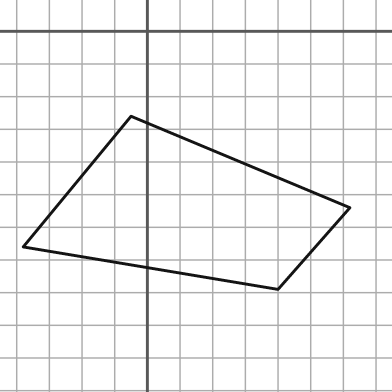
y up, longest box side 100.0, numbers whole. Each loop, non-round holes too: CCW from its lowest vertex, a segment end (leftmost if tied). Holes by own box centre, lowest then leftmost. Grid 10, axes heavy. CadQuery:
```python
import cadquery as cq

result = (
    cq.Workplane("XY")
    .moveTo(40.0, -79.0)
    .lineTo(62.0, -54.0)
    .lineTo(-5.0, -26.0)
    .lineTo(-38.0, -66.0)
    .close()
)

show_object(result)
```